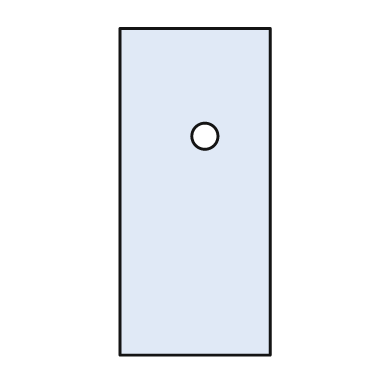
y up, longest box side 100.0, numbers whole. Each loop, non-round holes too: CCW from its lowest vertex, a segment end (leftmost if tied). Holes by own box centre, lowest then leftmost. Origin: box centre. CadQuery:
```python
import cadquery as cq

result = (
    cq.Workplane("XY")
    .moveTo(-23.0, -50.0)
    .lineTo(23.0, -50.0)
    .lineTo(23.0, 50.0)
    .lineTo(-23.0, 50.0)
    .close()
    .moveTo(3.0, 17.0)
    .circle(4.0)
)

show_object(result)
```